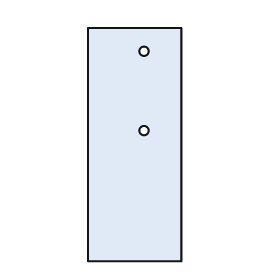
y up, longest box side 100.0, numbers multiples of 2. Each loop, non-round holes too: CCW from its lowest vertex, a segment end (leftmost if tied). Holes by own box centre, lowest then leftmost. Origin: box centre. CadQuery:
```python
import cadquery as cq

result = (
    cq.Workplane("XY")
    .moveTo(-20.0, -50.0)
    .lineTo(20.0, -50.0)
    .lineTo(20.0, 50.0)
    .lineTo(-20.0, 50.0)
    .close()
    .moveTo(4.0, 6.0)
    .circle(2.0)
    .moveTo(4.0, 40.0)
    .circle(2.0)
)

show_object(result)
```